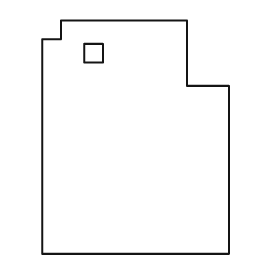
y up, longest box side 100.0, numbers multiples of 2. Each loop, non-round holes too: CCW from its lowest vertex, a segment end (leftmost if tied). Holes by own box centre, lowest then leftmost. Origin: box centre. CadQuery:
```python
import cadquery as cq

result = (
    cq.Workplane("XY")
    .moveTo(-40.0, -50.0)
    .lineTo(40.0, -50.0)
    .lineTo(40.0, 22.0)
    .lineTo(22.0, 22.0)
    .lineTo(22.0, 50.0)
    .lineTo(-32.0, 50.0)
    .lineTo(-32.0, 42.0)
    .lineTo(-40.0, 42.0)
    .close()
    .moveTo(-22.0, 32.0)
    .lineTo(-14.0, 32.0)
    .lineTo(-14.0, 40.0)
    .lineTo(-22.0, 40.0)
    .close()
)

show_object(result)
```